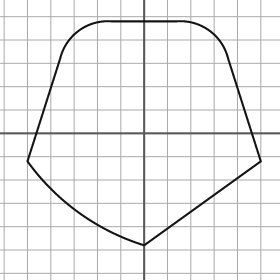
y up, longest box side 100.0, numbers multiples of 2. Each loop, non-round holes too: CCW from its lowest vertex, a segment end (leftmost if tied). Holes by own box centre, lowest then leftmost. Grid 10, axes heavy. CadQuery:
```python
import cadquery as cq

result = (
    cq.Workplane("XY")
    .moveTo(0.0, -48.0)
    .lineTo(50.0, -12.0)
    .lineTo(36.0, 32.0)
    .threePointArc((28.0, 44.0), (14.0, 48.0))
    .lineTo(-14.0, 48.0)
    .threePointArc((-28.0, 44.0), (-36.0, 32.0))
    .lineTo(-50.0, -12.0)
    .threePointArc((-28.0, -34.0), (0.0, -48.0))
    .close()
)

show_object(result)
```